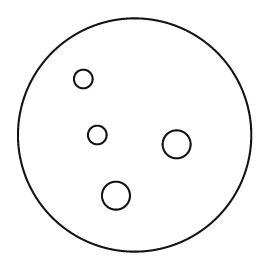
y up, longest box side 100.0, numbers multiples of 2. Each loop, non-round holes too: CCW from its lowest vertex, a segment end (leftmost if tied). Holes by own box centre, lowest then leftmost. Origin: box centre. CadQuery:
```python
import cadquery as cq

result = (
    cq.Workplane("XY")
    .moveTo(0.0, 0.0)
    .circle(50.0)
    .moveTo(-8.0, -26.0)
    .circle(6.0)
    .moveTo(18.0, -4.0)
    .circle(6.0)
    .moveTo(-16.0, 0.0)
    .circle(4.0)
    .moveTo(-22.0, 24.0)
    .circle(4.0)
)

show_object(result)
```